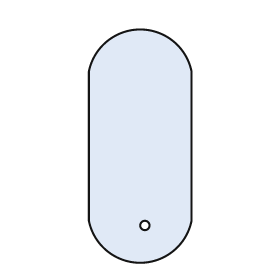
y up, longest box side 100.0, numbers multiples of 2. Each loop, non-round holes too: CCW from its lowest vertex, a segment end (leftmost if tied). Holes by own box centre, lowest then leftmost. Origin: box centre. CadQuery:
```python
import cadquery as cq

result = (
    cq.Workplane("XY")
    .moveTo(-22.0, -32.0)
    .threePointArc((0.0, -50.0), (22.0, -32.0))
    .lineTo(22.0, 32.0)
    .threePointArc((0.0, 50.0), (-22.0, 32.0))
    .close()
    .moveTo(2.0, -34.0)
    .circle(2.0)
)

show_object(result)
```